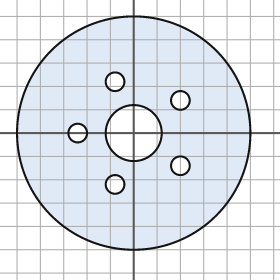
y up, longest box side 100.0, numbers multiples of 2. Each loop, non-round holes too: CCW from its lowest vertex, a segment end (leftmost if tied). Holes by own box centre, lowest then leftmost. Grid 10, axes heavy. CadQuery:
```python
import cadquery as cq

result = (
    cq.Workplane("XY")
    .moveTo(0.0, 0.0)
    .circle(50.0)
    .moveTo(-8.0, -22.0)
    .circle(4.0)
    .moveTo(20.0, -14.0)
    .circle(4.0)
    .moveTo(-24.0, 0.0)
    .circle(4.0)
    .moveTo(0.0, 0.0)
    .circle(12.0)
    .moveTo(20.0, 14.0)
    .circle(4.0)
    .moveTo(-8.0, 22.0)
    .circle(4.0)
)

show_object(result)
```